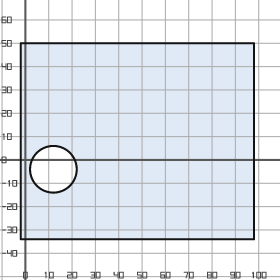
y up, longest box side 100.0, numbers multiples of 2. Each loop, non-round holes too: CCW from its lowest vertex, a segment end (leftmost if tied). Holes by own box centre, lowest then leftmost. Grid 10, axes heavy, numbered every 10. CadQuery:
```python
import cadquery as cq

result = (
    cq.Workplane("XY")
    .moveTo(-2.0, -34.0)
    .lineTo(98.0, -34.0)
    .lineTo(98.0, 50.0)
    .lineTo(-2.0, 50.0)
    .close()
    .moveTo(12.0, -4.0)
    .circle(10.0)
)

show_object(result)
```